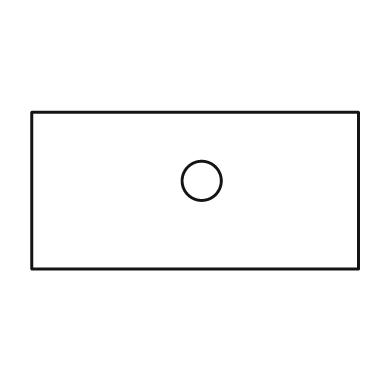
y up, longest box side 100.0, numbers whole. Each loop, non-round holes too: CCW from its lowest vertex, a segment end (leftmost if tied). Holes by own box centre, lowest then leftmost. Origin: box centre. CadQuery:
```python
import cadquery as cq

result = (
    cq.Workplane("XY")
    .moveTo(-50.0, -24.0)
    .lineTo(50.0, -24.0)
    .lineTo(50.0, 24.0)
    .lineTo(-50.0, 24.0)
    .close()
    .moveTo(2.0, 3.0)
    .circle(6.0)
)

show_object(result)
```